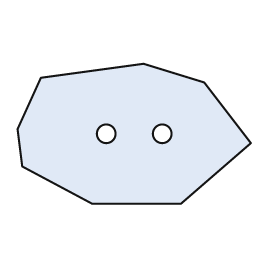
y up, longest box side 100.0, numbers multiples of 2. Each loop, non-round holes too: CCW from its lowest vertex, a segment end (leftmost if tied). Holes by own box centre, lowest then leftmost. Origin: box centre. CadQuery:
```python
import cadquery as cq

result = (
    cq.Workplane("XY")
    .moveTo(-18.0, -30.0)
    .lineTo(20.0, -30.0)
    .lineTo(50.0, -4.0)
    .lineTo(30.0, 22.0)
    .lineTo(4.0, 30.0)
    .lineTo(-40.0, 24.0)
    .lineTo(-50.0, 2.0)
    .lineTo(-48.0, -14.0)
    .close()
    .moveTo(-12.0, 0.0)
    .circle(4.0)
    .moveTo(12.0, 0.0)
    .circle(4.0)
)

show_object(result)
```